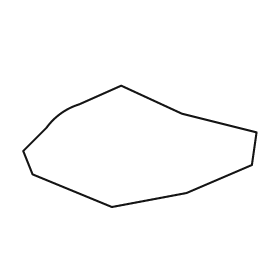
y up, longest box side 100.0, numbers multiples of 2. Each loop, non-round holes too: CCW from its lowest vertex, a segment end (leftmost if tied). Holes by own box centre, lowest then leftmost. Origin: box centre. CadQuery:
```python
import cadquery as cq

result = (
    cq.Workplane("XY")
    .moveTo(-12.0, -26.0)
    .lineTo(20.0, -20.0)
    .lineTo(48.0, -8.0)
    .lineTo(50.0, 6.0)
    .lineTo(18.0, 14.0)
    .lineTo(-8.0, 26.0)
    .lineTo(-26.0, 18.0)
    .threePointArc((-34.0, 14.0), (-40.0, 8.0))
    .lineTo(-50.0, -2.0)
    .lineTo(-46.0, -12.0)
    .close()
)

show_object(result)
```